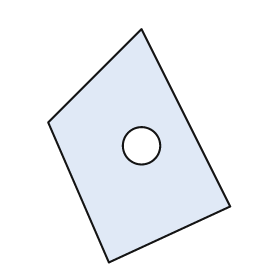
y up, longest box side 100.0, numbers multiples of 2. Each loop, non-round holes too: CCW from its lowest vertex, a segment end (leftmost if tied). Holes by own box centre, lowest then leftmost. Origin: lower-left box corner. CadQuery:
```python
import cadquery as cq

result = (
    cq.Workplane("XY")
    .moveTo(26.0, 0.0)
    .lineTo(78.0, 24.0)
    .lineTo(40.0, 100.0)
    .lineTo(0.0, 60.0)
    .close()
    .moveTo(40.0, 50.0)
    .circle(8.0)
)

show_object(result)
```